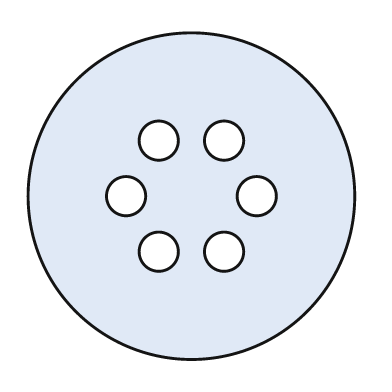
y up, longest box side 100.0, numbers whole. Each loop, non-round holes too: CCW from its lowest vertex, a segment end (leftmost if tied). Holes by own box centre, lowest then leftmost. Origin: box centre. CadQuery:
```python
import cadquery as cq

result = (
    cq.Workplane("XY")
    .moveTo(0.0, 0.0)
    .circle(50.0)
    .moveTo(-10.0, -17.0)
    .circle(6.0)
    .moveTo(10.0, -17.0)
    .circle(6.0)
    .moveTo(-20.0, 0.0)
    .circle(6.0)
    .moveTo(20.0, 0.0)
    .circle(6.0)
    .moveTo(-10.0, 17.0)
    .circle(6.0)
    .moveTo(10.0, 17.0)
    .circle(6.0)
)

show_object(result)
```